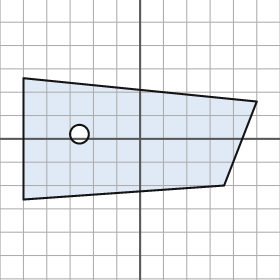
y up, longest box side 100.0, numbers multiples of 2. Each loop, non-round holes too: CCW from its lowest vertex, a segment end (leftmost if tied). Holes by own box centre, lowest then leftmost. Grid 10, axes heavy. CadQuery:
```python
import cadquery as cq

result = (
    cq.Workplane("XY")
    .moveTo(-50.0, -26.0)
    .lineTo(36.0, -20.0)
    .lineTo(50.0, 16.0)
    .lineTo(-50.0, 26.0)
    .close()
    .moveTo(-26.0, 2.0)
    .circle(4.0)
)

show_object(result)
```